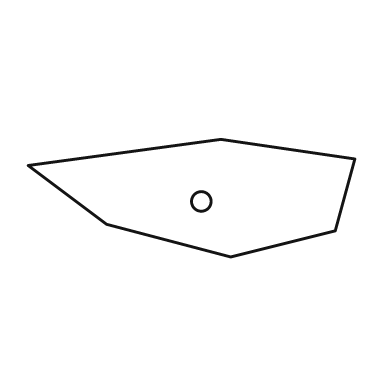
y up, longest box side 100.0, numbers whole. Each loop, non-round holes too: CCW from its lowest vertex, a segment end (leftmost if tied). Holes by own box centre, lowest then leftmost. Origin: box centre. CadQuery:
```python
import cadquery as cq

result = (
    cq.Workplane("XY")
    .moveTo(12.0, -18.0)
    .lineTo(44.0, -10.0)
    .lineTo(50.0, 12.0)
    .lineTo(9.0, 18.0)
    .lineTo(-50.0, 10.0)
    .lineTo(-26.0, -8.0)
    .close()
    .moveTo(3.0, -1.0)
    .circle(3.0)
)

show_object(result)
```